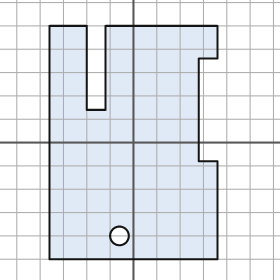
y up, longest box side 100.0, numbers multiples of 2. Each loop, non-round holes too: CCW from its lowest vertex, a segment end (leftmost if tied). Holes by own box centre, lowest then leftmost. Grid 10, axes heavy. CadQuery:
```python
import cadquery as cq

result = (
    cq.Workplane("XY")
    .moveTo(-36.0, -50.0)
    .lineTo(36.0, -50.0)
    .lineTo(36.0, -8.0)
    .lineTo(28.0, -8.0)
    .lineTo(28.0, 36.0)
    .lineTo(36.0, 36.0)
    .lineTo(36.0, 50.0)
    .lineTo(-12.0, 50.0)
    .lineTo(-12.0, 14.0)
    .lineTo(-20.0, 14.0)
    .lineTo(-20.0, 50.0)
    .lineTo(-36.0, 50.0)
    .close()
    .moveTo(-6.0, -40.0)
    .circle(4.0)
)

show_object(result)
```